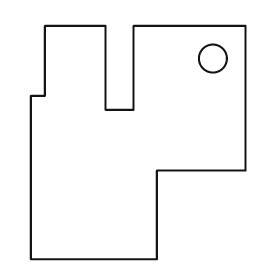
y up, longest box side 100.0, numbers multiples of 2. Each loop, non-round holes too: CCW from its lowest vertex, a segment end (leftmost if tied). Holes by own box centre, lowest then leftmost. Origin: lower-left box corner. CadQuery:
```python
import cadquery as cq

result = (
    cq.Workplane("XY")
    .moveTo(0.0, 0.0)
    .lineTo(54.0, 0.0)
    .lineTo(54.0, 38.0)
    .lineTo(92.0, 38.0)
    .lineTo(92.0, 100.0)
    .lineTo(44.0, 100.0)
    .lineTo(44.0, 64.0)
    .lineTo(32.0, 64.0)
    .lineTo(32.0, 100.0)
    .lineTo(6.0, 100.0)
    .lineTo(6.0, 70.0)
    .lineTo(0.0, 70.0)
    .close()
    .moveTo(78.0, 86.0)
    .circle(6.0)
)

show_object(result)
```